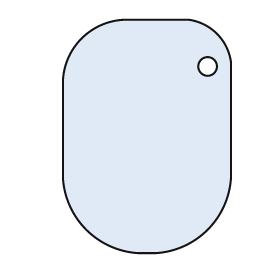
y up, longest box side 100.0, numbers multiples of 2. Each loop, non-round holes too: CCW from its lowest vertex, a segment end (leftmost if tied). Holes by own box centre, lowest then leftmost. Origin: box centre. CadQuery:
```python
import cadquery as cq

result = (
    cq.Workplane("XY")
    .moveTo(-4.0, -50.0)
    .lineTo(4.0, -50.0)
    .threePointArc((26.0, -40.0), (36.0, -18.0))
    .lineTo(36.0, 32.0)
    .threePointArc((30.0, 44.0), (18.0, 50.0))
    .lineTo(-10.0, 50.0)
    .threePointArc((-28.0, 42.0), (-36.0, 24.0))
    .lineTo(-36.0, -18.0)
    .threePointArc((-26.0, -40.0), (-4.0, -50.0))
    .close()
    .moveTo(26.0, 30.0)
    .circle(4.0)
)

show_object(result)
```